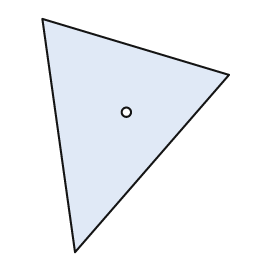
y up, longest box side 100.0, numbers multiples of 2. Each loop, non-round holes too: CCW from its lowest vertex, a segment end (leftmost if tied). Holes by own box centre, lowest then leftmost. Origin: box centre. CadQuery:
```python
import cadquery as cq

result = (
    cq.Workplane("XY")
    .moveTo(-26.0, -50.0)
    .lineTo(40.0, 26.0)
    .lineTo(-40.0, 50.0)
    .close()
    .moveTo(-4.0, 10.0)
    .circle(2.0)
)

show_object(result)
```